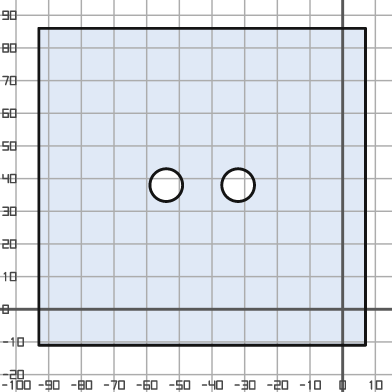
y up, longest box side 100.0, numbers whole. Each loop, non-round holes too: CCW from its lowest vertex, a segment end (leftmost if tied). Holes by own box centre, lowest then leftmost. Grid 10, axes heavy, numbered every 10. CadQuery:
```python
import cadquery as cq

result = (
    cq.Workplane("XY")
    .moveTo(-93.0, -11.0)
    .lineTo(7.0, -11.0)
    .lineTo(7.0, 86.0)
    .lineTo(-93.0, 86.0)
    .close()
    .moveTo(-54.0, 38.0)
    .circle(5.0)
    .moveTo(-32.0, 38.0)
    .circle(5.0)
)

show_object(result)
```